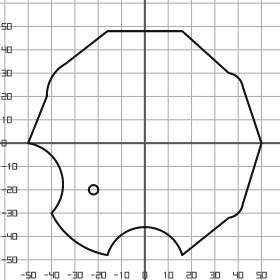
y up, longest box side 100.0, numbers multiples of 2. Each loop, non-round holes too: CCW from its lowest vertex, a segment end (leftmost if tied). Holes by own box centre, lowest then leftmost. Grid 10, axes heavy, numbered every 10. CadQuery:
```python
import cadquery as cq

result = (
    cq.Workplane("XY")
    .moveTo(-16.0, -48.0)
    .threePointArc((0.0, -36.0), (16.0, -48.0))
    .lineTo(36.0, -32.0)
    .threePointArc((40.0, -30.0), (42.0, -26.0))
    .lineTo(50.0, 0.0)
    .lineTo(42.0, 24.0)
    .threePointArc((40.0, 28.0), (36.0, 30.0))
    .lineTo(16.0, 48.0)
    .lineTo(-16.0, 48.0)
    .lineTo(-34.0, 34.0)
    .threePointArc((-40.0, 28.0), (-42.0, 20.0))
    .lineTo(-50.0, 0.0)
    .threePointArc((-36.0, -12.0), (-40.0, -30.0))
    .threePointArc((-30.0, -42.0), (-16.0, -48.0))
    .close()
    .moveTo(-22.0, -20.0)
    .circle(2.0)
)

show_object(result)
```